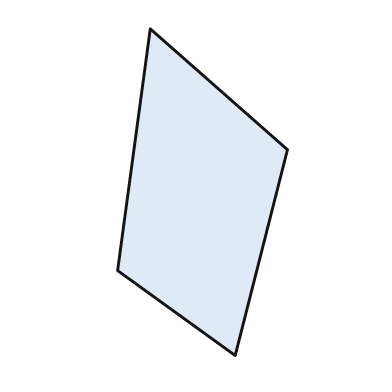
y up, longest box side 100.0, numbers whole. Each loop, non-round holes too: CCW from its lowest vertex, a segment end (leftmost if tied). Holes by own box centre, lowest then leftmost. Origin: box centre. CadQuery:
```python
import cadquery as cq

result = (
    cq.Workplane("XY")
    .moveTo(10.0, -50.0)
    .lineTo(26.0, 13.0)
    .lineTo(-16.0, 50.0)
    .lineTo(-26.0, -24.0)
    .close()
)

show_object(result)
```